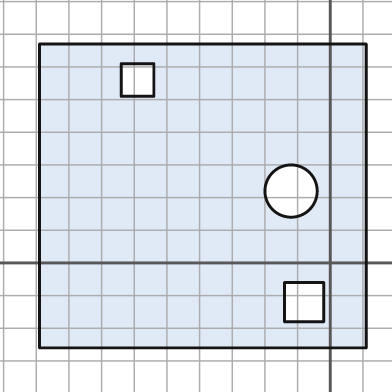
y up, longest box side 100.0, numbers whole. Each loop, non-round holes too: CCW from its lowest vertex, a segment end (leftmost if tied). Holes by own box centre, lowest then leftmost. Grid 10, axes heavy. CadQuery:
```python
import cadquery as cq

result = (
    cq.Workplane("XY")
    .moveTo(-89.0, -26.0)
    .lineTo(11.0, -26.0)
    .lineTo(11.0, 67.0)
    .lineTo(-89.0, 67.0)
    .close()
    .moveTo(-14.0, -18.0)
    .lineTo(-2.0, -18.0)
    .lineTo(-2.0, -6.0)
    .lineTo(-14.0, -6.0)
    .close()
    .moveTo(-12.0, 22.0)
    .circle(8.0)
    .moveTo(-64.0, 51.0)
    .lineTo(-54.0, 51.0)
    .lineTo(-54.0, 61.0)
    .lineTo(-64.0, 61.0)
    .close()
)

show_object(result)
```